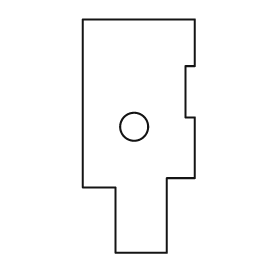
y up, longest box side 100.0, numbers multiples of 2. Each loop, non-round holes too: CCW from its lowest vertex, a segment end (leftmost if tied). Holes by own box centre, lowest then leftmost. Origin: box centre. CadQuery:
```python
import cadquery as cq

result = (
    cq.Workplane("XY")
    .moveTo(-10.0, -50.0)
    .lineTo(12.0, -50.0)
    .lineTo(12.0, -18.0)
    .lineTo(24.0, -18.0)
    .lineTo(24.0, 8.0)
    .lineTo(20.0, 8.0)
    .lineTo(20.0, 30.0)
    .lineTo(24.0, 30.0)
    .lineTo(24.0, 50.0)
    .lineTo(-24.0, 50.0)
    .lineTo(-24.0, -22.0)
    .lineTo(-10.0, -22.0)
    .close()
    .moveTo(-2.0, 4.0)
    .circle(6.0)
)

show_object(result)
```